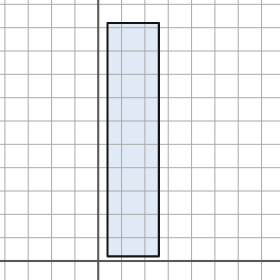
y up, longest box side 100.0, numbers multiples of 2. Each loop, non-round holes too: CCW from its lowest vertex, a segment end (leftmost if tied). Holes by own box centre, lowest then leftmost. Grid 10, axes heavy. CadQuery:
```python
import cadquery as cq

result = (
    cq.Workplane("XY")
    .moveTo(4.0, 2.0)
    .lineTo(26.0, 2.0)
    .lineTo(26.0, 102.0)
    .lineTo(4.0, 102.0)
    .close()
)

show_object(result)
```